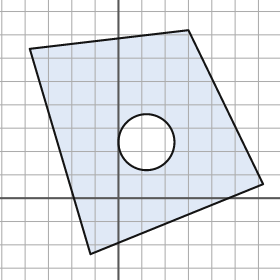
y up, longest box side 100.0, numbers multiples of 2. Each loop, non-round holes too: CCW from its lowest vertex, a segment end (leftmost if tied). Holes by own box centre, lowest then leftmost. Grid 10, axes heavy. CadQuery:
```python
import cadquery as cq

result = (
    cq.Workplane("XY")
    .moveTo(-12.0, -24.0)
    .lineTo(62.0, 6.0)
    .lineTo(30.0, 72.0)
    .lineTo(-38.0, 64.0)
    .close()
    .moveTo(12.0, 24.0)
    .circle(12.0)
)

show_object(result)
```